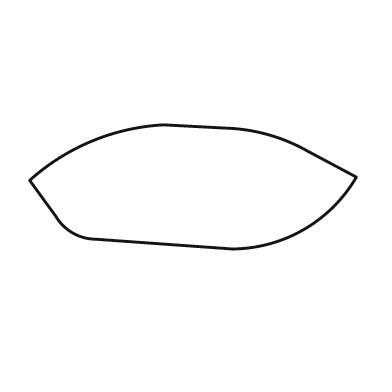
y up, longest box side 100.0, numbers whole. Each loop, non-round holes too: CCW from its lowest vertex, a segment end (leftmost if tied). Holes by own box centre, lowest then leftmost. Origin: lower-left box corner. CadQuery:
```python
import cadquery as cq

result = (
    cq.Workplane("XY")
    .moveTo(62.0, 0.0)
    .threePointArc((84.0, 6.0), (100.0, 22.0))
    .lineTo(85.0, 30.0)
    .threePointArc((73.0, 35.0), (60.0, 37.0))
    .lineTo(41.0, 38.0)
    .threePointArc((19.0, 33.0), (0.0, 21.0))
    .lineTo(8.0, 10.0)
    .threePointArc((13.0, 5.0), (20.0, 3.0))
    .close()
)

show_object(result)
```